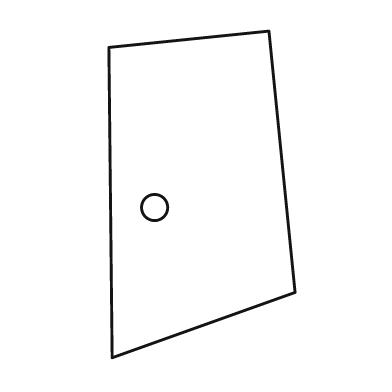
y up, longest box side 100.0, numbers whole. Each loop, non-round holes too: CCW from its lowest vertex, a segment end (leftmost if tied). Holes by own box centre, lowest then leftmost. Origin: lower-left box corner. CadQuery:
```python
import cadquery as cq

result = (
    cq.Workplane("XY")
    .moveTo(1.0, 0.0)
    .lineTo(57.0, 20.0)
    .lineTo(49.0, 100.0)
    .lineTo(0.0, 95.0)
    .close()
    .moveTo(14.0, 46.0)
    .circle(4.0)
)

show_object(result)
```